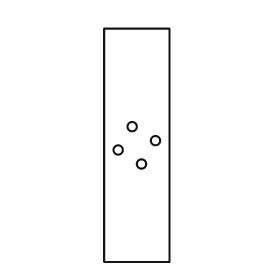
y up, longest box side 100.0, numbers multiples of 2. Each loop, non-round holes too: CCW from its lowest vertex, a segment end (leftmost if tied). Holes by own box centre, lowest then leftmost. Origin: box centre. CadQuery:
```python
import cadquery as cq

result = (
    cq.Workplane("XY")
    .moveTo(-14.0, -50.0)
    .lineTo(14.0, -50.0)
    .lineTo(14.0, 50.0)
    .lineTo(-14.0, 50.0)
    .close()
    .moveTo(2.0, -8.0)
    .circle(2.0)
    .moveTo(-8.0, -2.0)
    .circle(2.0)
    .moveTo(8.0, 2.0)
    .circle(2.0)
    .moveTo(-2.0, 8.0)
    .circle(2.0)
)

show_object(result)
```